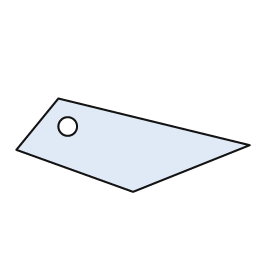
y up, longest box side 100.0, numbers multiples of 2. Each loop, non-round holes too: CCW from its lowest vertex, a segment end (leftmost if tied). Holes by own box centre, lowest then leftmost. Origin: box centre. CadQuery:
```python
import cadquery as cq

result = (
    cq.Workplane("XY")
    .moveTo(0.0, -20.0)
    .lineTo(50.0, 0.0)
    .lineTo(-32.0, 20.0)
    .lineTo(-50.0, -2.0)
    .close()
    .moveTo(-28.0, 8.0)
    .circle(4.0)
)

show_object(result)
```